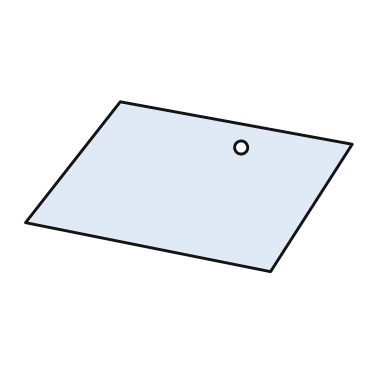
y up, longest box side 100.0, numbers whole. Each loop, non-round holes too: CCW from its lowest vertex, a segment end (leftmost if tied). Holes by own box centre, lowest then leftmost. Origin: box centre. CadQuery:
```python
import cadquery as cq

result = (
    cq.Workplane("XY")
    .moveTo(25.0, -26.0)
    .lineTo(50.0, 13.0)
    .lineTo(-21.0, 26.0)
    .lineTo(-50.0, -11.0)
    .close()
    .moveTo(16.0, 12.0)
    .circle(2.0)
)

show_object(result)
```